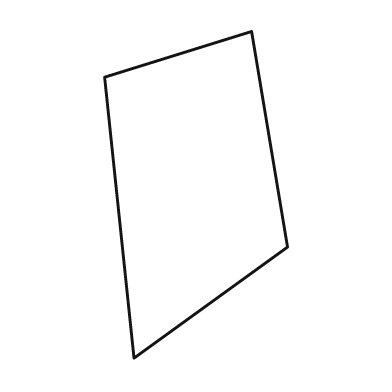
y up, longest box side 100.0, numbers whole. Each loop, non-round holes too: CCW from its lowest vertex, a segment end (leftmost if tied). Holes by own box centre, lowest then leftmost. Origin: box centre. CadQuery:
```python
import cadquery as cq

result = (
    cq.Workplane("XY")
    .moveTo(-19.0, -50.0)
    .lineTo(28.0, -16.0)
    .lineTo(17.0, 50.0)
    .lineTo(-28.0, 36.0)
    .close()
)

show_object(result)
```